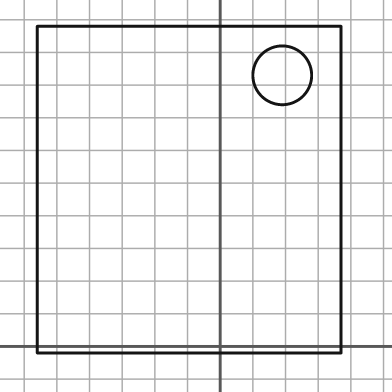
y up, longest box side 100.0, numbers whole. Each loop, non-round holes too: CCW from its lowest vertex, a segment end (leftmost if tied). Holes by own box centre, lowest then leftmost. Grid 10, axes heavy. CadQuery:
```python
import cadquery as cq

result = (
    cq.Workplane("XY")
    .moveTo(-56.0, -2.0)
    .lineTo(37.0, -2.0)
    .lineTo(37.0, 98.0)
    .lineTo(-56.0, 98.0)
    .close()
    .moveTo(19.0, 83.0)
    .circle(9.0)
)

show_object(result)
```